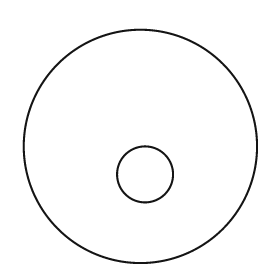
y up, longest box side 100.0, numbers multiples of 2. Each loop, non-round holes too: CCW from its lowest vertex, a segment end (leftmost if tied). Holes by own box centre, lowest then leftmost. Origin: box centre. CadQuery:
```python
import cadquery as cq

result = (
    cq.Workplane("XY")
    .moveTo(0.0, 0.0)
    .circle(50.0)
    .moveTo(2.0, -12.0)
    .circle(12.0)
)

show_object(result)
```